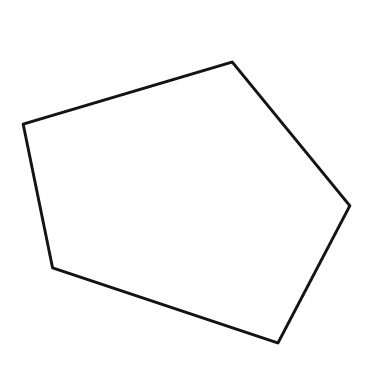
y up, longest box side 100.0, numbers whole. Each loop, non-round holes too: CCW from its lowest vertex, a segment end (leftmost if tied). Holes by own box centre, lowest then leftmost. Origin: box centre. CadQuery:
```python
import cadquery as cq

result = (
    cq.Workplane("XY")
    .moveTo(28.0, -43.0)
    .lineTo(50.0, -1.0)
    .lineTo(14.0, 43.0)
    .lineTo(-50.0, 24.0)
    .lineTo(-41.0, -20.0)
    .close()
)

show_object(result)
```